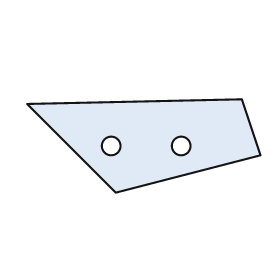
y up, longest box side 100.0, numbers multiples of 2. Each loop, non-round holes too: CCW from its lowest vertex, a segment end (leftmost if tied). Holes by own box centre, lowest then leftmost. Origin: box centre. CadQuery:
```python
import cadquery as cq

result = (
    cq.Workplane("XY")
    .moveTo(-12.0, -20.0)
    .lineTo(50.0, -4.0)
    .lineTo(42.0, 20.0)
    .lineTo(-50.0, 18.0)
    .close()
    .moveTo(-14.0, 0.0)
    .circle(4.0)
    .moveTo(16.0, 0.0)
    .circle(4.0)
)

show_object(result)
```